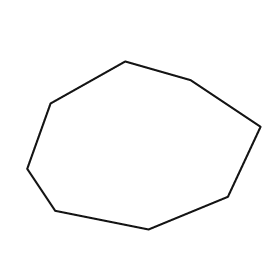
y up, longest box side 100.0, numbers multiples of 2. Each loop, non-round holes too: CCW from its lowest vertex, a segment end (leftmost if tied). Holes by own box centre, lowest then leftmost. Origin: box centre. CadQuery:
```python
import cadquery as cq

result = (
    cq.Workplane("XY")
    .moveTo(2.0, -36.0)
    .lineTo(36.0, -22.0)
    .lineTo(50.0, 8.0)
    .lineTo(20.0, 28.0)
    .lineTo(-8.0, 36.0)
    .lineTo(-40.0, 18.0)
    .lineTo(-50.0, -10.0)
    .lineTo(-38.0, -28.0)
    .close()
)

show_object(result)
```